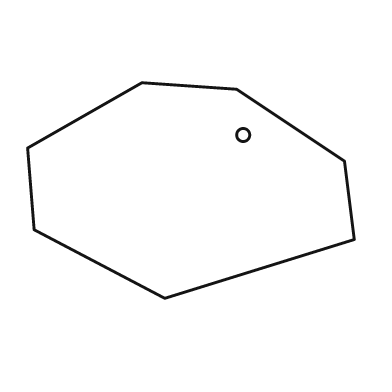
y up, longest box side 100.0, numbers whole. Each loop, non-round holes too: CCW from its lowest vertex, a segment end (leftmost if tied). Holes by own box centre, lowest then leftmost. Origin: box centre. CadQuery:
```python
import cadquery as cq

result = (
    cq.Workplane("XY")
    .moveTo(-8.0, -33.0)
    .lineTo(50.0, -15.0)
    .lineTo(47.0, 9.0)
    .lineTo(14.0, 31.0)
    .lineTo(-15.0, 33.0)
    .lineTo(-50.0, 13.0)
    .lineTo(-48.0, -12.0)
    .close()
    .moveTo(16.0, 17.0)
    .circle(2.0)
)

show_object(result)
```